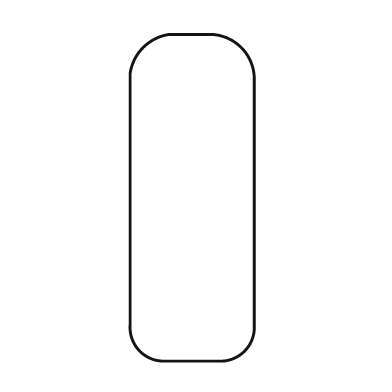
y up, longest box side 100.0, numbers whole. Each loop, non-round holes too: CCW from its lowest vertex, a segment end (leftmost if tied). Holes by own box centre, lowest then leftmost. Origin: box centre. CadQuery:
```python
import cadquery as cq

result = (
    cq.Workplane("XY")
    .moveTo(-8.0, -50.0)
    .lineTo(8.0, -50.0)
    .threePointArc((16.0, -47.0), (19.0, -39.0))
    .lineTo(19.0, 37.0)
    .threePointArc((15.0, 46.0), (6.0, 50.0))
    .lineTo(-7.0, 50.0)
    .threePointArc((-15.0, 46.0), (-19.0, 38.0))
    .lineTo(-19.0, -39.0)
    .threePointArc((-16.0, -47.0), (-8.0, -50.0))
    .close()
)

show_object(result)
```